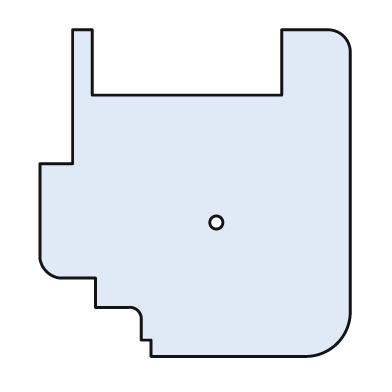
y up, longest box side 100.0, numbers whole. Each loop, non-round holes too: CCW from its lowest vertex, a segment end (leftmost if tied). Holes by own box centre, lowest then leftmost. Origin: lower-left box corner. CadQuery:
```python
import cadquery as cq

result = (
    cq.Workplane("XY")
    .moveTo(34.0, 0.0)
    .lineTo(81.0, 0.0)
    .threePointArc((91.0, 4.0), (95.0, 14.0))
    .lineTo(95.0, 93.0)
    .threePointArc((93.0, 98.0), (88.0, 100.0))
    .lineTo(74.0, 100.0)
    .lineTo(74.0, 80.0)
    .lineTo(16.0, 80.0)
    .lineTo(16.0, 100.0)
    .lineTo(10.0, 100.0)
    .lineTo(10.0, 59.0)
    .lineTo(0.0, 59.0)
    .lineTo(0.0, 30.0)
    .threePointArc((2.0, 26.0), (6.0, 24.0))
    .lineTo(17.0, 24.0)
    .lineTo(17.0, 15.0)
    .lineTo(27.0, 15.0)
    .threePointArc((30.0, 14.0), (31.0, 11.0))
    .lineTo(31.0, 5.0)
    .lineTo(34.0, 5.0)
    .close()
    .moveTo(54.0, 41.0)
    .circle(2.0)
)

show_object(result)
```